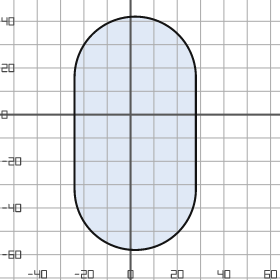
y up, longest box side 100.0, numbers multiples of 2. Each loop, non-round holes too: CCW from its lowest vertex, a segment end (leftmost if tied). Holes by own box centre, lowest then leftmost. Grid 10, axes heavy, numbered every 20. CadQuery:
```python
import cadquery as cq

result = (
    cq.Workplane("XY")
    .moveTo(-24.0, -32.0)
    .threePointArc((2.0, -58.0), (28.0, -32.0))
    .lineTo(28.0, 16.0)
    .threePointArc((2.0, 42.0), (-24.0, 16.0))
    .close()
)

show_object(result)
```